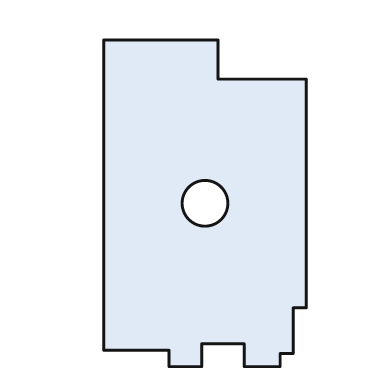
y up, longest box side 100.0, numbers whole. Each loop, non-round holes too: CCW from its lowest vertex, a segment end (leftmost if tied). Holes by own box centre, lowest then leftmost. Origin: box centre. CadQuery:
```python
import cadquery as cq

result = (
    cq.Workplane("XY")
    .moveTo(-11.0, -50.0)
    .lineTo(-1.0, -50.0)
    .lineTo(-1.0, -43.0)
    .lineTo(12.0, -43.0)
    .lineTo(12.0, -50.0)
    .lineTo(23.0, -50.0)
    .lineTo(23.0, -46.0)
    .lineTo(27.0, -46.0)
    .lineTo(27.0, -32.0)
    .lineTo(31.0, -32.0)
    .lineTo(31.0, 38.0)
    .lineTo(4.0, 38.0)
    .lineTo(4.0, 50.0)
    .lineTo(-31.0, 50.0)
    .lineTo(-31.0, -45.0)
    .lineTo(-11.0, -45.0)
    .close()
    .moveTo(0.0, 0.0)
    .circle(7.0)
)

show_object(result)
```